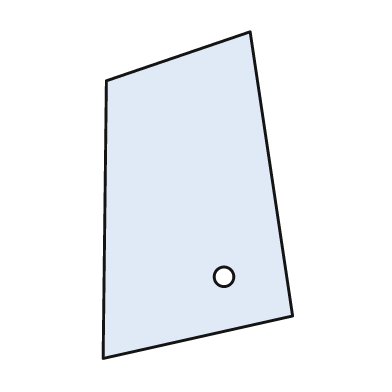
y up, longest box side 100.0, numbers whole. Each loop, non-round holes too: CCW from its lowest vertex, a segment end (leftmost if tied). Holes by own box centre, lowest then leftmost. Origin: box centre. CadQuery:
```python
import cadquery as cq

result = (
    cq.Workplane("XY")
    .moveTo(-29.0, -50.0)
    .lineTo(29.0, -37.0)
    .lineTo(16.0, 50.0)
    .lineTo(-28.0, 35.0)
    .close()
    .moveTo(8.0, -25.0)
    .circle(3.0)
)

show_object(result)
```